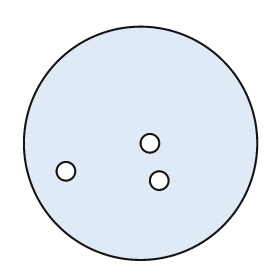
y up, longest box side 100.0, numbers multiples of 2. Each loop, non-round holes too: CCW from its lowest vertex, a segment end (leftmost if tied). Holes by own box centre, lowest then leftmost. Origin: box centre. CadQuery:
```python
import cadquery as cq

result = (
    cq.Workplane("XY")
    .moveTo(0.0, 0.0)
    .circle(50.0)
    .moveTo(8.0, -16.0)
    .circle(4.0)
    .moveTo(-32.0, -12.0)
    .circle(4.0)
    .moveTo(4.0, 0.0)
    .circle(4.0)
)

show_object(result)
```